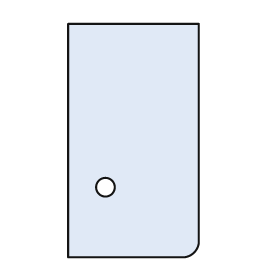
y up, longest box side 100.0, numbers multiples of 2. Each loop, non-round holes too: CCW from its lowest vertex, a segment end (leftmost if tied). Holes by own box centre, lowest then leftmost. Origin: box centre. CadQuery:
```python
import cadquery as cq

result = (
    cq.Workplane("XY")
    .moveTo(-28.0, -50.0)
    .lineTo(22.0, -50.0)
    .threePointArc((26.0, -48.0), (28.0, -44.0))
    .lineTo(28.0, 50.0)
    .lineTo(-28.0, 50.0)
    .close()
    .moveTo(-12.0, -20.0)
    .circle(4.0)
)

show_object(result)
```